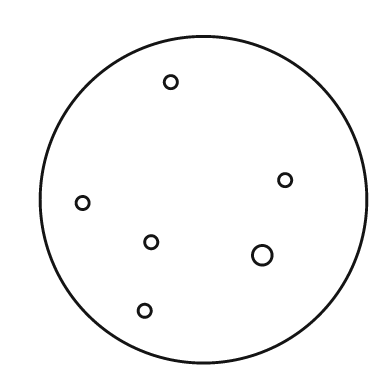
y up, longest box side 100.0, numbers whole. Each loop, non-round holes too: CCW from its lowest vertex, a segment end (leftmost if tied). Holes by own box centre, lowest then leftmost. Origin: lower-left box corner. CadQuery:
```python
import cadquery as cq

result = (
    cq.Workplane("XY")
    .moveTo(50.0, 50.0)
    .circle(50.0)
    .moveTo(32.0, 16.0)
    .circle(2.0)
    .moveTo(68.0, 33.0)
    .circle(3.0)
    .moveTo(34.0, 37.0)
    .circle(2.0)
    .moveTo(13.0, 49.0)
    .circle(2.0)
    .moveTo(75.0, 56.0)
    .circle(2.0)
    .moveTo(40.0, 86.0)
    .circle(2.0)
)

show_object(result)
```